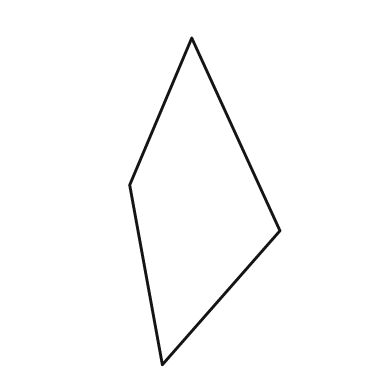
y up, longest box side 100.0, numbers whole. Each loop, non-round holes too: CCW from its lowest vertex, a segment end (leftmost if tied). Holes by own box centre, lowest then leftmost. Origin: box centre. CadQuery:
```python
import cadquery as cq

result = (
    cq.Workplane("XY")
    .moveTo(-13.0, -50.0)
    .lineTo(23.0, -9.0)
    .lineTo(-4.0, 50.0)
    .lineTo(-23.0, 5.0)
    .close()
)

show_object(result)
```